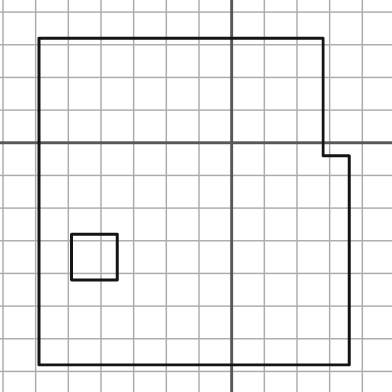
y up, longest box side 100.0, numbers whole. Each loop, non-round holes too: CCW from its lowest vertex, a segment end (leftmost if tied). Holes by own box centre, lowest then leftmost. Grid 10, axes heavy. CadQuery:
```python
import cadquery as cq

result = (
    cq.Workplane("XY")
    .moveTo(-59.0, -68.0)
    .lineTo(36.0, -68.0)
    .lineTo(36.0, -4.0)
    .lineTo(28.0, -4.0)
    .lineTo(28.0, 32.0)
    .lineTo(-59.0, 32.0)
    .close()
    .moveTo(-49.0, -42.0)
    .lineTo(-35.0, -42.0)
    .lineTo(-35.0, -28.0)
    .lineTo(-49.0, -28.0)
    .close()
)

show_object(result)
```